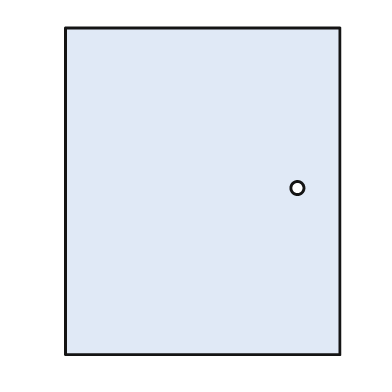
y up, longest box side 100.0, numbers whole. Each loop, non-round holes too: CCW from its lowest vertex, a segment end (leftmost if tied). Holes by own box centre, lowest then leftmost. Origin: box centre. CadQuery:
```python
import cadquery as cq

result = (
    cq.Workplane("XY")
    .moveTo(-42.0, -50.0)
    .lineTo(42.0, -50.0)
    .lineTo(42.0, 50.0)
    .lineTo(-42.0, 50.0)
    .close()
    .moveTo(29.0, 1.0)
    .circle(2.0)
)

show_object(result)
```